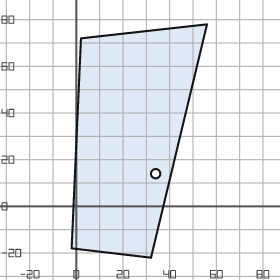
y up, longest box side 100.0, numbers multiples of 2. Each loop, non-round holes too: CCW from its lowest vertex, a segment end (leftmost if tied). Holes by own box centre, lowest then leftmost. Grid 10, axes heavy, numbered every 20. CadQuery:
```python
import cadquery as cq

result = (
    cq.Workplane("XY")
    .moveTo(32.0, -22.0)
    .lineTo(56.0, 78.0)
    .lineTo(2.0, 72.0)
    .lineTo(-2.0, -18.0)
    .close()
    .moveTo(34.0, 14.0)
    .circle(2.0)
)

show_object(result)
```